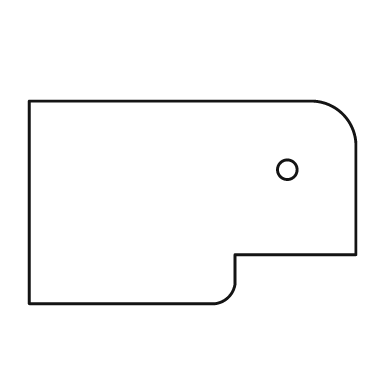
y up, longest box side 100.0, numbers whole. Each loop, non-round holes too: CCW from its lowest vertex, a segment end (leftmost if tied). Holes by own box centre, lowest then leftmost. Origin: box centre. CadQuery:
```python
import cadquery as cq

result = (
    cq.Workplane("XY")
    .moveTo(-50.0, -31.0)
    .lineTo(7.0, -31.0)
    .threePointArc((11.0, -29.0), (13.0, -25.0))
    .lineTo(13.0, -16.0)
    .lineTo(50.0, -16.0)
    .lineTo(50.0, 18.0)
    .threePointArc((46.0, 27.0), (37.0, 31.0))
    .lineTo(-50.0, 31.0)
    .close()
    .moveTo(29.0, 10.0)
    .circle(3.0)
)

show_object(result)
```